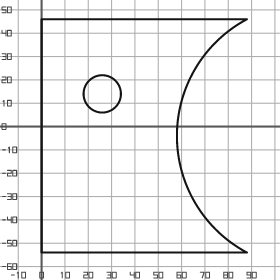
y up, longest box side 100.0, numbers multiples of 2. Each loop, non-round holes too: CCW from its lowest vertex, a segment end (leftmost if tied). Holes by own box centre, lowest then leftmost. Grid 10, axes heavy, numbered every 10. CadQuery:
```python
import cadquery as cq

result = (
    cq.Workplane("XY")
    .moveTo(0.0, -54.0)
    .lineTo(88.0, -54.0)
    .threePointArc((58.0, -4.0), (88.0, 46.0))
    .lineTo(0.0, 46.0)
    .close()
    .moveTo(26.0, 14.0)
    .circle(8.0)
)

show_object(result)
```